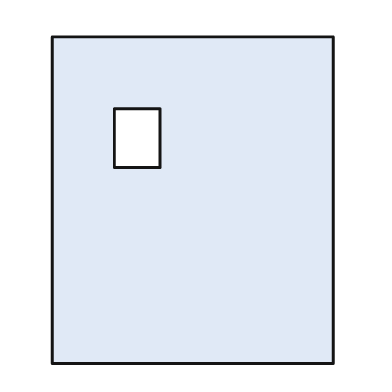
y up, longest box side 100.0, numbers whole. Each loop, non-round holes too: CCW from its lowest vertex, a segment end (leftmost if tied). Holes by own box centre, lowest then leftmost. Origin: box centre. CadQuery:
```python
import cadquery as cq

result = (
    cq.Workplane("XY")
    .moveTo(-43.0, -50.0)
    .lineTo(43.0, -50.0)
    .lineTo(43.0, 50.0)
    .lineTo(-43.0, 50.0)
    .close()
    .moveTo(-24.0, 10.0)
    .lineTo(-10.0, 10.0)
    .lineTo(-10.0, 28.0)
    .lineTo(-24.0, 28.0)
    .close()
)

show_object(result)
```